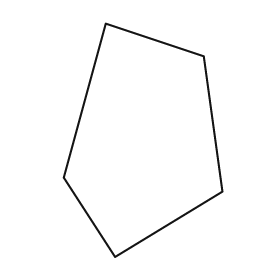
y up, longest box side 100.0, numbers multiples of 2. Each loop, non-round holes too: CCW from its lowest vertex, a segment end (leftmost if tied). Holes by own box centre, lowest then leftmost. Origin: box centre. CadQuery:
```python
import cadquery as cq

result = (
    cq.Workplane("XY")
    .moveTo(-12.0, -50.0)
    .lineTo(34.0, -22.0)
    .lineTo(26.0, 36.0)
    .lineTo(-16.0, 50.0)
    .lineTo(-34.0, -16.0)
    .close()
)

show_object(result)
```